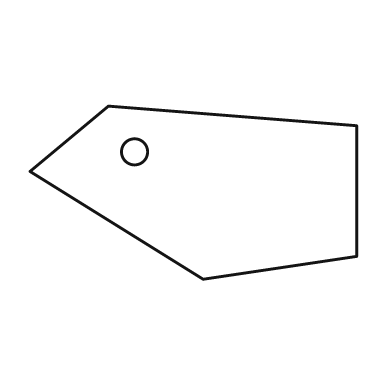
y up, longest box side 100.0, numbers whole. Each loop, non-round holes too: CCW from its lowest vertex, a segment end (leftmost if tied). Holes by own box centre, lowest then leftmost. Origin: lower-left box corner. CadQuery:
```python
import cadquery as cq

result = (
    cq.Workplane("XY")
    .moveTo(53.0, 0.0)
    .lineTo(100.0, 7.0)
    .lineTo(100.0, 47.0)
    .lineTo(24.0, 53.0)
    .lineTo(0.0, 33.0)
    .close()
    .moveTo(32.0, 39.0)
    .circle(4.0)
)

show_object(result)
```